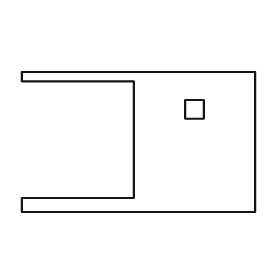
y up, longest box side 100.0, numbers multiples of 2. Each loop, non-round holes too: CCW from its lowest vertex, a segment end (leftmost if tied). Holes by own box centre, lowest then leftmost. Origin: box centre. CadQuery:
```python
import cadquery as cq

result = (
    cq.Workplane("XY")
    .moveTo(-50.0, -30.0)
    .lineTo(50.0, -30.0)
    .lineTo(50.0, 30.0)
    .lineTo(-50.0, 30.0)
    .lineTo(-50.0, 26.0)
    .lineTo(-2.0, 26.0)
    .lineTo(-2.0, -24.0)
    .lineTo(-50.0, -24.0)
    .close()
    .moveTo(20.0, 10.0)
    .lineTo(28.0, 10.0)
    .lineTo(28.0, 18.0)
    .lineTo(20.0, 18.0)
    .close()
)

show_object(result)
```